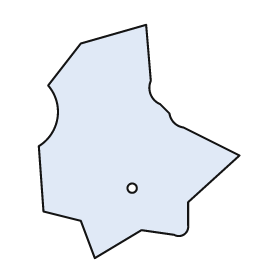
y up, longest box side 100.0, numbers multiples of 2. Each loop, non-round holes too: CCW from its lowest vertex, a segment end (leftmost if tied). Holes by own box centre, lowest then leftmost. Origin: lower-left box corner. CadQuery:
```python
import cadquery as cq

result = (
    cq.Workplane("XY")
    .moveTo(24.0, 0.0)
    .lineTo(44.0, 12.0)
    .lineTo(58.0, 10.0)
    .threePointArc((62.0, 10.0), (64.0, 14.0))
    .lineTo(64.0, 24.0)
    .lineTo(86.0, 44.0)
    .lineTo(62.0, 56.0)
    .threePointArc((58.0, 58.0), (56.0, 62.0))
    .lineTo(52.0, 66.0)
    .threePointArc((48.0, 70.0), (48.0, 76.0))
    .lineTo(46.0, 100.0)
    .lineTo(18.0, 92.0)
    .lineTo(4.0, 74.0)
    .threePointArc((8.0, 60.0), (0.0, 48.0))
    .lineTo(2.0, 20.0)
    .lineTo(18.0, 16.0)
    .close()
    .moveTo(40.0, 30.0)
    .circle(2.0)
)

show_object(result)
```